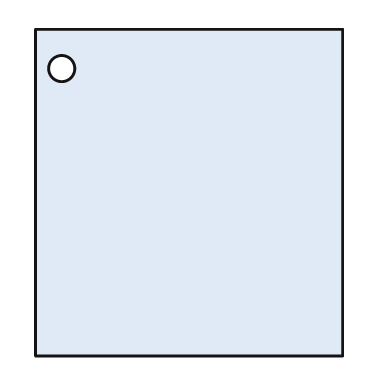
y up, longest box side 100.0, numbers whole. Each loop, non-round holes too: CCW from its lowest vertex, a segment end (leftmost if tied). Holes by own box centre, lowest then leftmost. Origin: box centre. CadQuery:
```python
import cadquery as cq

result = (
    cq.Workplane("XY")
    .moveTo(-47.0, -50.0)
    .lineTo(47.0, -50.0)
    .lineTo(47.0, 50.0)
    .lineTo(-47.0, 50.0)
    .close()
    .moveTo(-39.0, 38.0)
    .circle(4.0)
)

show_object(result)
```